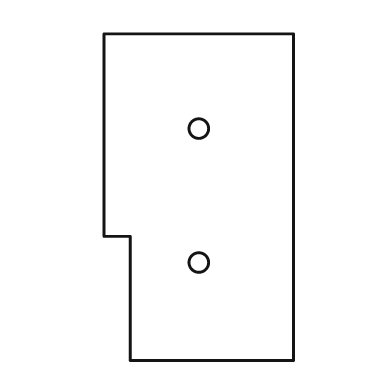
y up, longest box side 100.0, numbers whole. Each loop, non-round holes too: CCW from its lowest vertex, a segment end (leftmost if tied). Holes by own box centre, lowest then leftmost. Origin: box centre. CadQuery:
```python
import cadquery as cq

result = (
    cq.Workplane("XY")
    .moveTo(-21.0, -50.0)
    .lineTo(29.0, -50.0)
    .lineTo(29.0, 50.0)
    .lineTo(-29.0, 50.0)
    .lineTo(-29.0, -12.0)
    .lineTo(-21.0, -12.0)
    .close()
    .moveTo(0.0, -20.0)
    .circle(3.0)
    .moveTo(0.0, 21.0)
    .circle(3.0)
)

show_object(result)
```